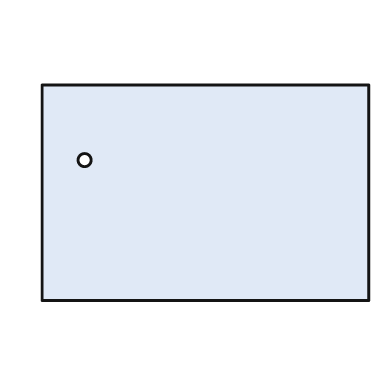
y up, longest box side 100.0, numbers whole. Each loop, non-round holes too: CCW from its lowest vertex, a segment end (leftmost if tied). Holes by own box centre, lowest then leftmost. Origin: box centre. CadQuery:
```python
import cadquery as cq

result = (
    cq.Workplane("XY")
    .moveTo(-50.0, -33.0)
    .lineTo(50.0, -33.0)
    .lineTo(50.0, 33.0)
    .lineTo(-50.0, 33.0)
    .close()
    .moveTo(-37.0, 10.0)
    .circle(2.0)
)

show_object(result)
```